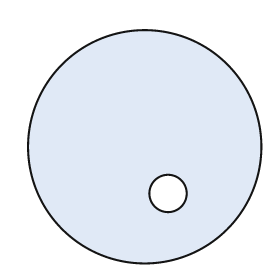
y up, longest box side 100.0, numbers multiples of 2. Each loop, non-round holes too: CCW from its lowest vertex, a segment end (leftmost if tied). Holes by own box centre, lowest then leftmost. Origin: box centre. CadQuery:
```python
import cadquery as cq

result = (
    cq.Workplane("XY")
    .moveTo(0.0, 0.0)
    .circle(50.0)
    .moveTo(10.0, -20.0)
    .circle(8.0)
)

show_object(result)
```